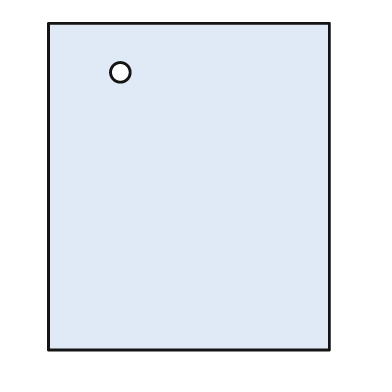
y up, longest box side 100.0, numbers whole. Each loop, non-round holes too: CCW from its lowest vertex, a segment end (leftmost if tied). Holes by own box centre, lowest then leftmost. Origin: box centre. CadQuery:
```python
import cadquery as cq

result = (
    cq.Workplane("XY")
    .moveTo(-43.0, -50.0)
    .lineTo(43.0, -50.0)
    .lineTo(43.0, 50.0)
    .lineTo(-43.0, 50.0)
    .close()
    .moveTo(-21.0, 35.0)
    .circle(3.0)
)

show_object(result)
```